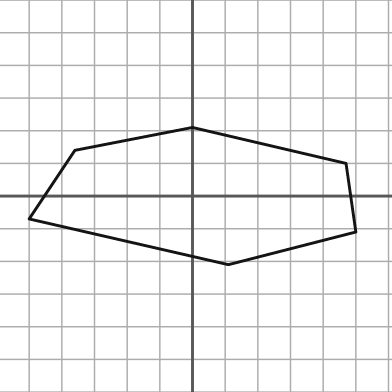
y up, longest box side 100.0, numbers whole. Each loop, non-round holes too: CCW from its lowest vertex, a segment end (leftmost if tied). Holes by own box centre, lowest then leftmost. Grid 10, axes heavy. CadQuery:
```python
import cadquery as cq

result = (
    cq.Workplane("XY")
    .moveTo(11.0, -21.0)
    .lineTo(50.0, -11.0)
    .lineTo(47.0, 10.0)
    .lineTo(0.0, 21.0)
    .lineTo(-36.0, 14.0)
    .lineTo(-50.0, -7.0)
    .close()
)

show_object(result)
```